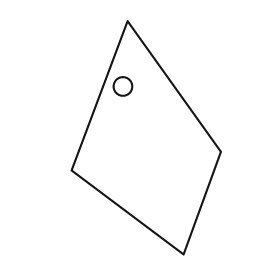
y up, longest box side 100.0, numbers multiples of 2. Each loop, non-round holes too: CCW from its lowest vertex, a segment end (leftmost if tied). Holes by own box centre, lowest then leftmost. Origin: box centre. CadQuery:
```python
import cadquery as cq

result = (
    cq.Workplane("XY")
    .moveTo(16.0, -50.0)
    .lineTo(32.0, -6.0)
    .lineTo(-8.0, 50.0)
    .lineTo(-32.0, -14.0)
    .close()
    .moveTo(-10.0, 22.0)
    .circle(4.0)
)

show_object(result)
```